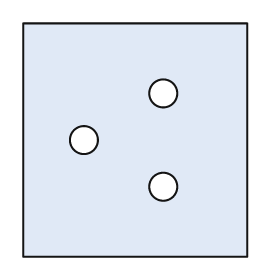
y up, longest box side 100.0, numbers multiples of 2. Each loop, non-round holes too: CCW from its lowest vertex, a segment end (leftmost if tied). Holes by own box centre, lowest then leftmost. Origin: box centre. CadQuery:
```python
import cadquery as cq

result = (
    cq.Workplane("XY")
    .moveTo(-48.0, -50.0)
    .lineTo(48.0, -50.0)
    .lineTo(48.0, 50.0)
    .lineTo(-48.0, 50.0)
    .close()
    .moveTo(12.0, -20.0)
    .circle(6.0)
    .moveTo(-22.0, 0.0)
    .circle(6.0)
    .moveTo(12.0, 20.0)
    .circle(6.0)
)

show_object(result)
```